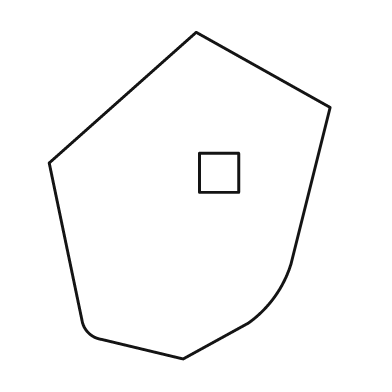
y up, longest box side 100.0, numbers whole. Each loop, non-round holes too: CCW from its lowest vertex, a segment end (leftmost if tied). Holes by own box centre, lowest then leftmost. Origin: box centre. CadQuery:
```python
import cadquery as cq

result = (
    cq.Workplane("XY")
    .moveTo(-2.0, -50.0)
    .lineTo(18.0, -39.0)
    .threePointArc((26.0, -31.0), (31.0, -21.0))
    .lineTo(43.0, 27.0)
    .lineTo(2.0, 50.0)
    .lineTo(-43.0, 10.0)
    .lineTo(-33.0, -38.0)
    .threePointArc((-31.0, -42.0), (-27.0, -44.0))
    .close()
    .moveTo(3.0, 1.0)
    .lineTo(15.0, 1.0)
    .lineTo(15.0, 13.0)
    .lineTo(3.0, 13.0)
    .close()
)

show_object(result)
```